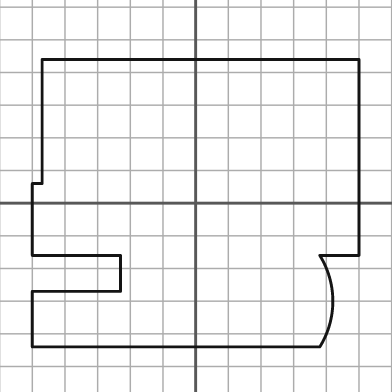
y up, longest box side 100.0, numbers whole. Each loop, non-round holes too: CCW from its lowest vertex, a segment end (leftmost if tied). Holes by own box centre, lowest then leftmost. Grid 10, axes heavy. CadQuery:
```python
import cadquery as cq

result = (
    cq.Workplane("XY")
    .moveTo(-50.0, -44.0)
    .lineTo(38.0, -44.0)
    .threePointArc((42.0, -30.0), (38.0, -16.0))
    .lineTo(50.0, -16.0)
    .lineTo(50.0, 44.0)
    .lineTo(-47.0, 44.0)
    .lineTo(-47.0, 6.0)
    .lineTo(-50.0, 6.0)
    .lineTo(-50.0, -16.0)
    .lineTo(-23.0, -16.0)
    .lineTo(-23.0, -27.0)
    .lineTo(-50.0, -27.0)
    .close()
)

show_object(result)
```